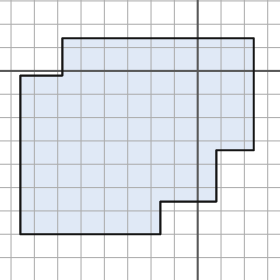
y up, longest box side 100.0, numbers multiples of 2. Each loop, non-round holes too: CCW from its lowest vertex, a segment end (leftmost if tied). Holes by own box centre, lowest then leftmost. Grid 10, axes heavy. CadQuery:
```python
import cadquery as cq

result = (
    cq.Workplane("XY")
    .moveTo(-76.0, -70.0)
    .lineTo(-16.0, -70.0)
    .lineTo(-16.0, -56.0)
    .lineTo(8.0, -56.0)
    .lineTo(8.0, -34.0)
    .lineTo(24.0, -34.0)
    .lineTo(24.0, 14.0)
    .lineTo(-58.0, 14.0)
    .lineTo(-58.0, -2.0)
    .lineTo(-76.0, -2.0)
    .close()
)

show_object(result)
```